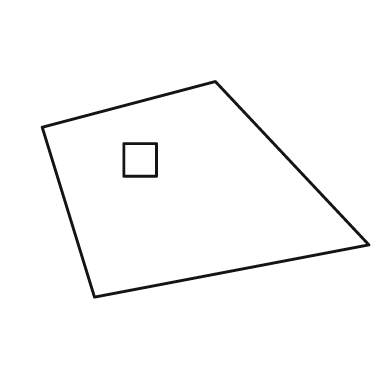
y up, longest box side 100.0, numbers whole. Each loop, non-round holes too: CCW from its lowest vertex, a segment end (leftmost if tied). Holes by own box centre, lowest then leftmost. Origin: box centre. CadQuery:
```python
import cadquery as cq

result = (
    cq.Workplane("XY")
    .moveTo(-34.0, -33.0)
    .lineTo(50.0, -17.0)
    .lineTo(3.0, 33.0)
    .lineTo(-50.0, 19.0)
    .close()
    .moveTo(-25.0, 4.0)
    .lineTo(-15.0, 4.0)
    .lineTo(-15.0, 14.0)
    .lineTo(-25.0, 14.0)
    .close()
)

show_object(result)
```